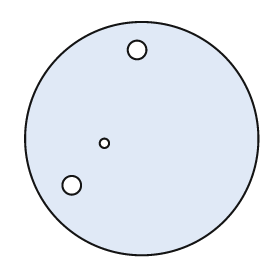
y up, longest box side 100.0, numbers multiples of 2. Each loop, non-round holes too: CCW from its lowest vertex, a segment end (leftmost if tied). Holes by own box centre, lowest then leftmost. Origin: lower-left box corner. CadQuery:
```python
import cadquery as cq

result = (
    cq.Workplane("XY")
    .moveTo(50.0, 50.0)
    .circle(50.0)
    .moveTo(20.0, 30.0)
    .circle(4.0)
    .moveTo(34.0, 48.0)
    .circle(2.0)
    .moveTo(48.0, 88.0)
    .circle(4.0)
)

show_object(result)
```